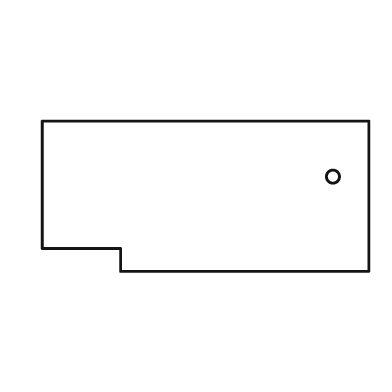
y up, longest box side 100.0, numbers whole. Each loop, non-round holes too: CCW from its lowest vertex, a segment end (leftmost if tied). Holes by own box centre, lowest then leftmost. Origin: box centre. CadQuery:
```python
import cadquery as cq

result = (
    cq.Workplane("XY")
    .moveTo(-26.0, -23.0)
    .lineTo(50.0, -23.0)
    .lineTo(50.0, 23.0)
    .lineTo(-50.0, 23.0)
    .lineTo(-50.0, -16.0)
    .lineTo(-26.0, -16.0)
    .close()
    .moveTo(39.0, 6.0)
    .circle(2.0)
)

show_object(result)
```